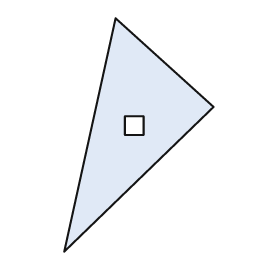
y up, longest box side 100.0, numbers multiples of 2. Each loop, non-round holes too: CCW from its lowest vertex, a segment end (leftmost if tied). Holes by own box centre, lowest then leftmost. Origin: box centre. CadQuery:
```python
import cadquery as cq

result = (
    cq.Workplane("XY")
    .moveTo(-32.0, -50.0)
    .lineTo(32.0, 12.0)
    .lineTo(-10.0, 50.0)
    .close()
    .moveTo(-6.0, 0.0)
    .lineTo(2.0, 0.0)
    .lineTo(2.0, 8.0)
    .lineTo(-6.0, 8.0)
    .close()
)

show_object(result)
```